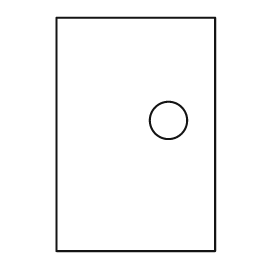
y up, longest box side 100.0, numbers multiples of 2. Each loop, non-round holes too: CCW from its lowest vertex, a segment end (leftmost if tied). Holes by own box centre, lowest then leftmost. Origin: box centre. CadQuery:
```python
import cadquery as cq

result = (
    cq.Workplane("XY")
    .moveTo(-34.0, -50.0)
    .lineTo(34.0, -50.0)
    .lineTo(34.0, 50.0)
    .lineTo(-34.0, 50.0)
    .close()
    .moveTo(14.0, 6.0)
    .circle(8.0)
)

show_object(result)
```